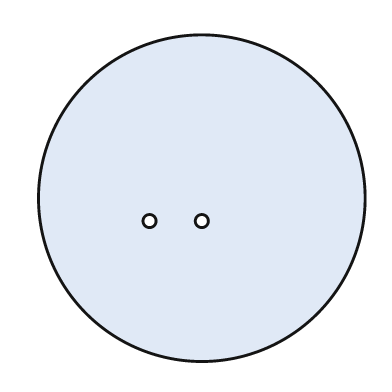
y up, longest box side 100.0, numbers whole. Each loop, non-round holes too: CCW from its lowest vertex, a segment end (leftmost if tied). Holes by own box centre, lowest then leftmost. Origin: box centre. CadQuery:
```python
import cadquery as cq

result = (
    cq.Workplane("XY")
    .moveTo(0.0, 0.0)
    .circle(50.0)
    .moveTo(-16.0, -7.0)
    .circle(2.0)
    .moveTo(0.0, -7.0)
    .circle(2.0)
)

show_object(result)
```